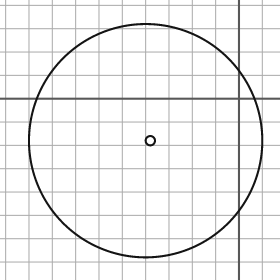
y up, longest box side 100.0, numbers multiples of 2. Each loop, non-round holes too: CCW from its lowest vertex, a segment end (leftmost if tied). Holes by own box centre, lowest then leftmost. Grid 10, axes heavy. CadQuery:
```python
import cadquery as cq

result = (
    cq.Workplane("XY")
    .moveTo(-40.0, -18.0)
    .circle(50.0)
    .moveTo(-38.0, -18.0)
    .circle(2.0)
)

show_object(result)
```